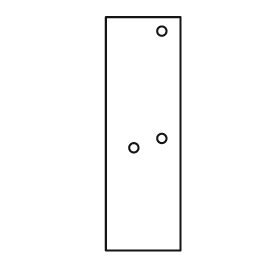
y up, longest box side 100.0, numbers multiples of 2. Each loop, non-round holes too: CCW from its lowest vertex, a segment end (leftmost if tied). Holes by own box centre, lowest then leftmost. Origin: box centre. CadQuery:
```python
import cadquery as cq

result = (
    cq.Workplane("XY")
    .moveTo(-16.0, -50.0)
    .lineTo(16.0, -50.0)
    .lineTo(16.0, 50.0)
    .lineTo(-16.0, 50.0)
    .close()
    .moveTo(-4.0, -6.0)
    .circle(2.0)
    .moveTo(8.0, -2.0)
    .circle(2.0)
    .moveTo(8.0, 44.0)
    .circle(2.0)
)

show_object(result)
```